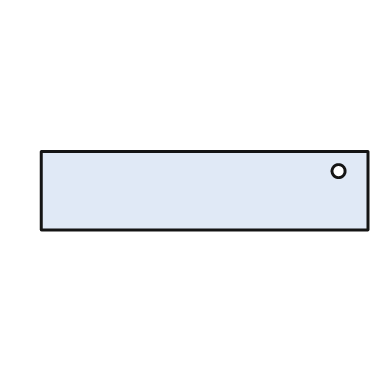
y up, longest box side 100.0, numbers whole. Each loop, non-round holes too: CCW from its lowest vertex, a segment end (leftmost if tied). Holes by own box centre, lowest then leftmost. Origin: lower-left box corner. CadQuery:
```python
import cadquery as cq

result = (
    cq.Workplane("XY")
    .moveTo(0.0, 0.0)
    .lineTo(100.0, 0.0)
    .lineTo(100.0, 24.0)
    .lineTo(0.0, 24.0)
    .close()
    .moveTo(91.0, 18.0)
    .circle(2.0)
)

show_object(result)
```